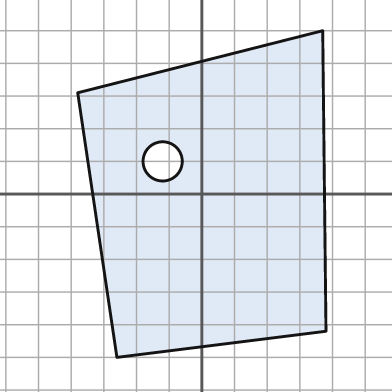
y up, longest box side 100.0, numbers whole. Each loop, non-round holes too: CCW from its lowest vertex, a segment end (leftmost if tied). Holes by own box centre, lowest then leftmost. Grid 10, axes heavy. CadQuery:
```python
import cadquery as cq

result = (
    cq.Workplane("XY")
    .moveTo(-26.0, -50.0)
    .lineTo(38.0, -42.0)
    .lineTo(37.0, 50.0)
    .lineTo(-38.0, 31.0)
    .close()
    .moveTo(-12.0, 10.0)
    .circle(6.0)
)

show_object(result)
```